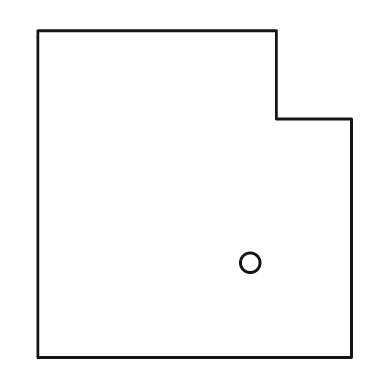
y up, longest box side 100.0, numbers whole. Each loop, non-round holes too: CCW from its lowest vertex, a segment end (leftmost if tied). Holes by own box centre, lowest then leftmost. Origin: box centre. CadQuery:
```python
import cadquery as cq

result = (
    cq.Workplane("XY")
    .moveTo(-48.0, -50.0)
    .lineTo(48.0, -50.0)
    .lineTo(48.0, 23.0)
    .lineTo(25.0, 23.0)
    .lineTo(25.0, 50.0)
    .lineTo(-48.0, 50.0)
    .close()
    .moveTo(17.0, -21.0)
    .circle(3.0)
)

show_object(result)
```